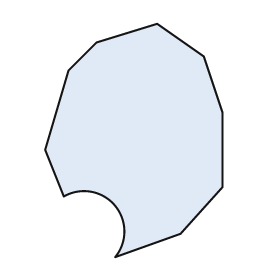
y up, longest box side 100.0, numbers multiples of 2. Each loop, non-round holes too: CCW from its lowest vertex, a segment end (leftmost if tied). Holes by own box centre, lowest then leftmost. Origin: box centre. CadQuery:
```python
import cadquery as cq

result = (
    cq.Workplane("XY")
    .moveTo(-8.0, -50.0)
    .lineTo(20.0, -40.0)
    .lineTo(38.0, -20.0)
    .lineTo(38.0, 12.0)
    .lineTo(30.0, 36.0)
    .lineTo(10.0, 50.0)
    .lineTo(-16.0, 42.0)
    .lineTo(-28.0, 30.0)
    .lineTo(-38.0, -4.0)
    .lineTo(-30.0, -24.0)
    .threePointArc((-8.0, -28.0), (-8.0, -50.0))
    .close()
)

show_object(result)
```